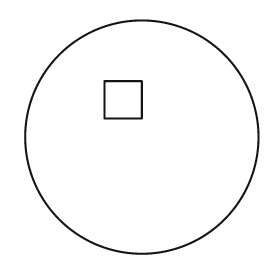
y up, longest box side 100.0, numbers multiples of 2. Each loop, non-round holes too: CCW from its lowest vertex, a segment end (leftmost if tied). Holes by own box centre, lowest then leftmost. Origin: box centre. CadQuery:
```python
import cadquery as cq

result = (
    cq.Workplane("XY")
    .moveTo(0.0, 0.0)
    .circle(50.0)
    .moveTo(-16.0, 8.0)
    .lineTo(0.0, 8.0)
    .lineTo(0.0, 24.0)
    .lineTo(-16.0, 24.0)
    .close()
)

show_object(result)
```